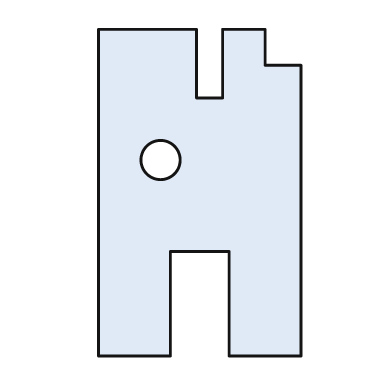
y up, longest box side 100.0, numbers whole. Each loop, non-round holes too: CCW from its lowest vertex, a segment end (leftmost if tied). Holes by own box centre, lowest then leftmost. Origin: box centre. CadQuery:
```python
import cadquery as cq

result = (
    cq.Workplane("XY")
    .moveTo(-31.0, -50.0)
    .lineTo(-9.0, -50.0)
    .lineTo(-9.0, -18.0)
    .lineTo(9.0, -18.0)
    .lineTo(9.0, -50.0)
    .lineTo(31.0, -50.0)
    .lineTo(31.0, 39.0)
    .lineTo(20.0, 39.0)
    .lineTo(20.0, 50.0)
    .lineTo(7.0, 50.0)
    .lineTo(7.0, 29.0)
    .lineTo(-1.0, 29.0)
    .lineTo(-1.0, 50.0)
    .lineTo(-31.0, 50.0)
    .close()
    .moveTo(-12.0, 10.0)
    .circle(6.0)
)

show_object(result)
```